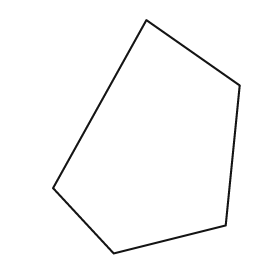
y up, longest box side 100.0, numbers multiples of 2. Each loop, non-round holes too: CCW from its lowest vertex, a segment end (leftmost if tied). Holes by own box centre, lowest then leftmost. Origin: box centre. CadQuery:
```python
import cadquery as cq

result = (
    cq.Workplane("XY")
    .moveTo(-14.0, -50.0)
    .lineTo(34.0, -38.0)
    .lineTo(40.0, 22.0)
    .lineTo(0.0, 50.0)
    .lineTo(-40.0, -22.0)
    .close()
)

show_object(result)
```